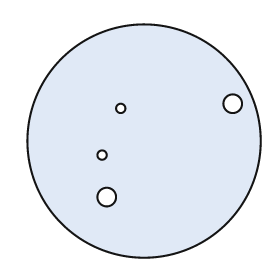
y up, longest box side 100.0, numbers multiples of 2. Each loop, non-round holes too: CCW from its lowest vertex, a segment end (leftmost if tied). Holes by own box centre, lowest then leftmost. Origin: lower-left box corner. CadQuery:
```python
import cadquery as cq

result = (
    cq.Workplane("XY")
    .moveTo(50.0, 50.0)
    .circle(50.0)
    .moveTo(34.0, 26.0)
    .circle(4.0)
    .moveTo(32.0, 44.0)
    .circle(2.0)
    .moveTo(40.0, 64.0)
    .circle(2.0)
    .moveTo(88.0, 66.0)
    .circle(4.0)
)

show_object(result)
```